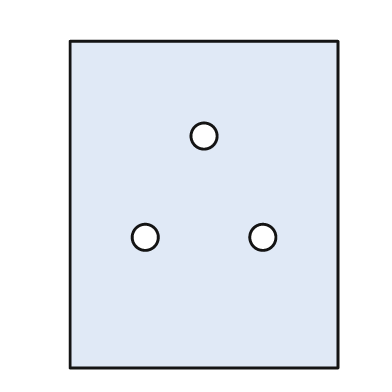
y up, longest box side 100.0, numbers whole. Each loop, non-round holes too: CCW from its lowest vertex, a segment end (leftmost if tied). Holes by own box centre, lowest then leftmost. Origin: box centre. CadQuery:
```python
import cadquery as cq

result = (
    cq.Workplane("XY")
    .moveTo(-41.0, -50.0)
    .lineTo(41.0, -50.0)
    .lineTo(41.0, 50.0)
    .lineTo(-41.0, 50.0)
    .close()
    .moveTo(-18.0, -10.0)
    .circle(4.0)
    .moveTo(18.0, -10.0)
    .circle(4.0)
    .moveTo(0.0, 21.0)
    .circle(4.0)
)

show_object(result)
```